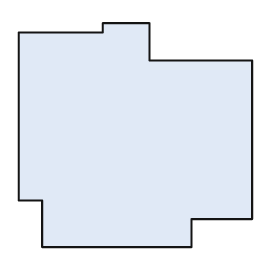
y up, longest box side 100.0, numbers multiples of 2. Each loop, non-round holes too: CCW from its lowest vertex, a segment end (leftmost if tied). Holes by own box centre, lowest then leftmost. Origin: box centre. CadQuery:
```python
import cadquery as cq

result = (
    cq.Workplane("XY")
    .moveTo(-40.0, -48.0)
    .lineTo(24.0, -48.0)
    .lineTo(24.0, -36.0)
    .lineTo(50.0, -36.0)
    .lineTo(50.0, 32.0)
    .lineTo(6.0, 32.0)
    .lineTo(6.0, 48.0)
    .lineTo(-14.0, 48.0)
    .lineTo(-14.0, 44.0)
    .lineTo(-50.0, 44.0)
    .lineTo(-50.0, -28.0)
    .lineTo(-40.0, -28.0)
    .close()
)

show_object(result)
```